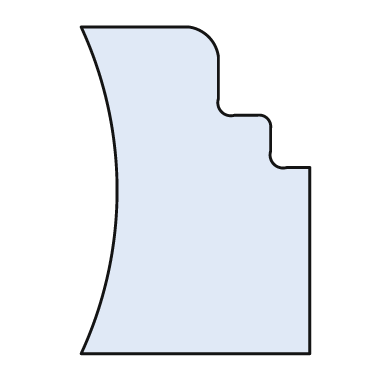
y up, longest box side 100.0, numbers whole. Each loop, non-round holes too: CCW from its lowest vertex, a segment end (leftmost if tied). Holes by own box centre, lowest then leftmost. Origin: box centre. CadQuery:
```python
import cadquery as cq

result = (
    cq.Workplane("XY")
    .moveTo(-35.0, -50.0)
    .lineTo(35.0, -50.0)
    .lineTo(35.0, 7.0)
    .lineTo(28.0, 7.0)
    .threePointArc((24.0, 8.0), (23.0, 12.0))
    .lineTo(23.0, 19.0)
    .threePointArc((22.0, 22.0), (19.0, 23.0))
    .lineTo(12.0, 23.0)
    .threePointArc((8.0, 24.0), (7.0, 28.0))
    .lineTo(7.0, 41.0)
    .threePointArc((4.0, 47.0), (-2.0, 50.0))
    .lineTo(-35.0, 50.0)
    .threePointArc((-24.0, 0.0), (-35.0, -50.0))
    .close()
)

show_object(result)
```